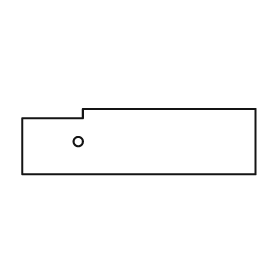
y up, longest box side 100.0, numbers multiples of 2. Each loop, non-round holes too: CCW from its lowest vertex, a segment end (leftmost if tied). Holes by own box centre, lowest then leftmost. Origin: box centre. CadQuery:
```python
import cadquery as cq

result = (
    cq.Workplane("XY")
    .moveTo(-50.0, -14.0)
    .lineTo(50.0, -14.0)
    .lineTo(50.0, 14.0)
    .lineTo(-24.0, 14.0)
    .lineTo(-24.0, 10.0)
    .lineTo(-50.0, 10.0)
    .close()
    .moveTo(-26.0, 0.0)
    .circle(2.0)
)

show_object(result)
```